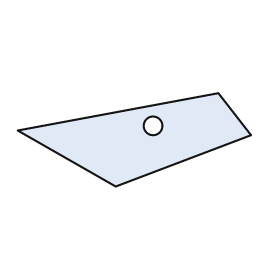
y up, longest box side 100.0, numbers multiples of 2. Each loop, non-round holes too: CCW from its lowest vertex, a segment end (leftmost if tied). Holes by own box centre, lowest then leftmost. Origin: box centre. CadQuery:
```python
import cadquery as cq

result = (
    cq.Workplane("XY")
    .moveTo(-8.0, -20.0)
    .lineTo(50.0, 2.0)
    .lineTo(36.0, 20.0)
    .lineTo(-50.0, 4.0)
    .close()
    .moveTo(8.0, 6.0)
    .circle(4.0)
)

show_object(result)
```